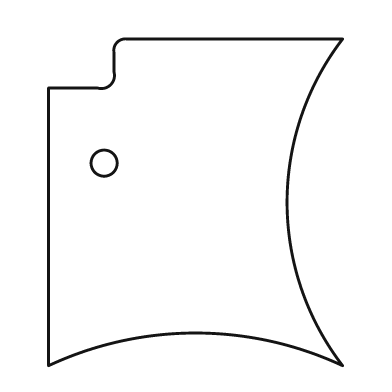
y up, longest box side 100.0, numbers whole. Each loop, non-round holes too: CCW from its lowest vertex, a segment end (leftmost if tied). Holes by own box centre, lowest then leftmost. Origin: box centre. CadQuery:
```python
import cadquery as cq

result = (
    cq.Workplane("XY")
    .moveTo(-45.0, -50.0)
    .threePointArc((0.0, -40.0), (45.0, -50.0))
    .threePointArc((28.0, 0.0), (45.0, 50.0))
    .lineTo(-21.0, 50.0)
    .threePointArc((-24.0, 49.0), (-25.0, 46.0))
    .lineTo(-25.0, 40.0)
    .threePointArc((-26.0, 36.0), (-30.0, 35.0))
    .lineTo(-45.0, 35.0)
    .close()
    .moveTo(-28.0, 12.0)
    .circle(4.0)
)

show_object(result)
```